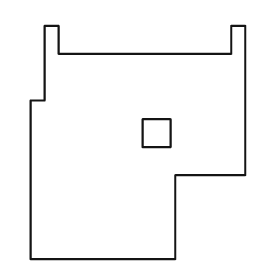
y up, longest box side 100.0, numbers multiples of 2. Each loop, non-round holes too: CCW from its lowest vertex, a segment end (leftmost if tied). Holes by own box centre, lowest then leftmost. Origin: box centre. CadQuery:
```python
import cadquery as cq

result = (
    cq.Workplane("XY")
    .moveTo(-46.0, -50.0)
    .lineTo(16.0, -50.0)
    .lineTo(16.0, -14.0)
    .lineTo(46.0, -14.0)
    .lineTo(46.0, 50.0)
    .lineTo(40.0, 50.0)
    .lineTo(40.0, 38.0)
    .lineTo(-34.0, 38.0)
    .lineTo(-34.0, 50.0)
    .lineTo(-40.0, 50.0)
    .lineTo(-40.0, 18.0)
    .lineTo(-46.0, 18.0)
    .close()
    .moveTo(2.0, -2.0)
    .lineTo(14.0, -2.0)
    .lineTo(14.0, 10.0)
    .lineTo(2.0, 10.0)
    .close()
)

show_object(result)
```